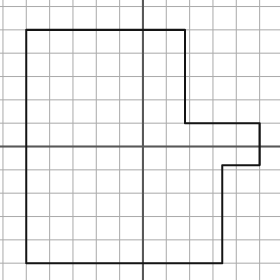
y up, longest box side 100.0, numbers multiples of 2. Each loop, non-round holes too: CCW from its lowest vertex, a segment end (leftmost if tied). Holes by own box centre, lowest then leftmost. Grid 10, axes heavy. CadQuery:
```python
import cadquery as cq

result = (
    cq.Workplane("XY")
    .moveTo(-50.0, -50.0)
    .lineTo(34.0, -50.0)
    .lineTo(34.0, -8.0)
    .lineTo(50.0, -8.0)
    .lineTo(50.0, 10.0)
    .lineTo(18.0, 10.0)
    .lineTo(18.0, 50.0)
    .lineTo(-50.0, 50.0)
    .close()
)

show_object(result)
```